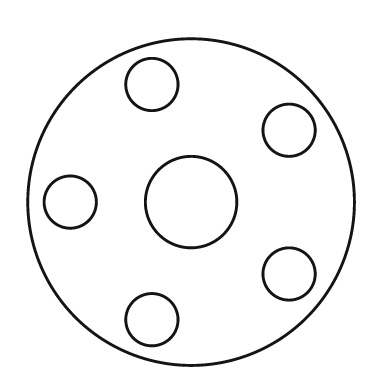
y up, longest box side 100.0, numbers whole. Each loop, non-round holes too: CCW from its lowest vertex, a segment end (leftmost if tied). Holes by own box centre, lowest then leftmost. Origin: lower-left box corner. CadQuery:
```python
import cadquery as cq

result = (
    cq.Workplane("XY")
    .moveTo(50.0, 50.0)
    .circle(50.0)
    .moveTo(38.0, 14.0)
    .circle(8.0)
    .moveTo(80.0, 28.0)
    .circle(8.0)
    .moveTo(13.0, 50.0)
    .circle(8.0)
    .moveTo(50.0, 50.0)
    .circle(14.0)
    .moveTo(80.0, 72.0)
    .circle(8.0)
    .moveTo(38.0, 86.0)
    .circle(8.0)
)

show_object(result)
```